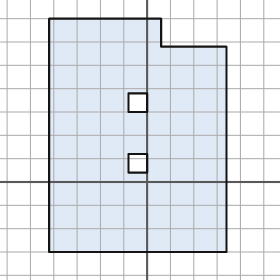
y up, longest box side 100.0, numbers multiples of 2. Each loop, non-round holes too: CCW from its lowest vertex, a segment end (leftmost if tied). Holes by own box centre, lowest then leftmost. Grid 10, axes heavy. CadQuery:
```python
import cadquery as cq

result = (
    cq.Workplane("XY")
    .moveTo(-42.0, -30.0)
    .lineTo(34.0, -30.0)
    .lineTo(34.0, 58.0)
    .lineTo(6.0, 58.0)
    .lineTo(6.0, 70.0)
    .lineTo(-42.0, 70.0)
    .close()
    .moveTo(-8.0, 4.0)
    .lineTo(0.0, 4.0)
    .lineTo(0.0, 12.0)
    .lineTo(-8.0, 12.0)
    .close()
    .moveTo(-8.0, 30.0)
    .lineTo(0.0, 30.0)
    .lineTo(0.0, 38.0)
    .lineTo(-8.0, 38.0)
    .close()
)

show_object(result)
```